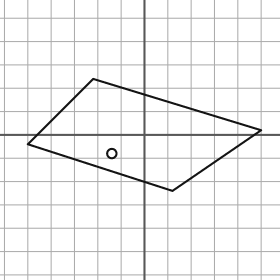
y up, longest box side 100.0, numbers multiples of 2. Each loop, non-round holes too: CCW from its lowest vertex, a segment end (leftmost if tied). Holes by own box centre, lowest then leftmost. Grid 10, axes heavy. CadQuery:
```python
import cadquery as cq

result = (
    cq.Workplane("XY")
    .moveTo(12.0, -24.0)
    .lineTo(50.0, 2.0)
    .lineTo(-22.0, 24.0)
    .lineTo(-50.0, -4.0)
    .close()
    .moveTo(-14.0, -8.0)
    .circle(2.0)
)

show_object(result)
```